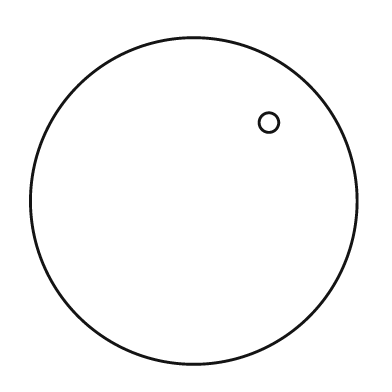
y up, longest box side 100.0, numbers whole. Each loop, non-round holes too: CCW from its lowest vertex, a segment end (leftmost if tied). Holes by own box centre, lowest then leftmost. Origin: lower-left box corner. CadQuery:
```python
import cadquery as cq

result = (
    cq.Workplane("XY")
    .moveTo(50.0, 50.0)
    .circle(50.0)
    .moveTo(73.0, 74.0)
    .circle(3.0)
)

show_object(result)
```